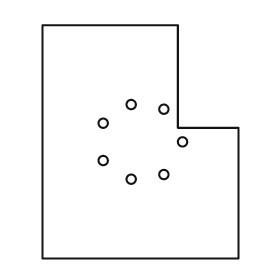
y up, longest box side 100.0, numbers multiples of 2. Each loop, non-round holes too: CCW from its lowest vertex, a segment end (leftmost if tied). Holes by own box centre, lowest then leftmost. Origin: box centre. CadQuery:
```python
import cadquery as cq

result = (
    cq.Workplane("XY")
    .moveTo(-42.0, -50.0)
    .lineTo(42.0, -50.0)
    .lineTo(42.0, 6.0)
    .lineTo(16.0, 6.0)
    .lineTo(16.0, 50.0)
    .lineTo(-42.0, 50.0)
    .close()
    .moveTo(-4.0, -16.0)
    .circle(2.0)
    .moveTo(10.0, -14.0)
    .circle(2.0)
    .moveTo(-16.0, -8.0)
    .circle(2.0)
    .moveTo(18.0, 0.0)
    .circle(2.0)
    .moveTo(-16.0, 8.0)
    .circle(2.0)
    .moveTo(10.0, 14.0)
    .circle(2.0)
    .moveTo(-4.0, 16.0)
    .circle(2.0)
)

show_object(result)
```